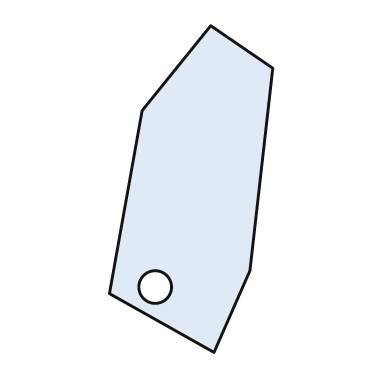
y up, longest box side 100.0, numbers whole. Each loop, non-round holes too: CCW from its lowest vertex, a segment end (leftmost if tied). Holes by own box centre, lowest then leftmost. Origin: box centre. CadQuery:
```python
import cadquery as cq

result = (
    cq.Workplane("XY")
    .moveTo(7.0, -50.0)
    .lineTo(18.0, -25.0)
    .lineTo(25.0, 37.0)
    .lineTo(6.0, 50.0)
    .lineTo(-15.0, 24.0)
    .lineTo(-25.0, -32.0)
    .close()
    .moveTo(-11.0, -30.0)
    .circle(5.0)
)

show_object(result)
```